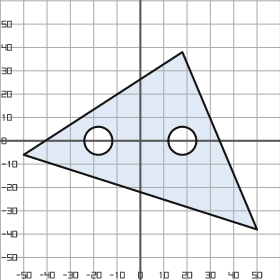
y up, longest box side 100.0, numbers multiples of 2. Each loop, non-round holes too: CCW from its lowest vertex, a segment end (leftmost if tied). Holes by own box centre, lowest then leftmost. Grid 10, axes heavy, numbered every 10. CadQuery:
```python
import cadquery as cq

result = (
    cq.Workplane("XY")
    .moveTo(50.0, -38.0)
    .lineTo(18.0, 38.0)
    .lineTo(-50.0, -6.0)
    .close()
    .moveTo(-18.0, 0.0)
    .circle(6.0)
    .moveTo(18.0, 0.0)
    .circle(6.0)
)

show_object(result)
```